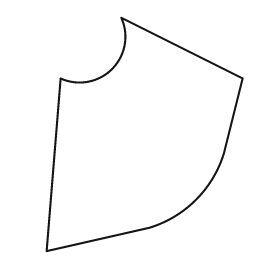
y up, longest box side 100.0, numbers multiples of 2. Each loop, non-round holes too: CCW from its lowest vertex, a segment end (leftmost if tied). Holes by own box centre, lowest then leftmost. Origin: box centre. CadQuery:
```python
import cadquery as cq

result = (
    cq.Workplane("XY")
    .moveTo(-42.0, -50.0)
    .lineTo(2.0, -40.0)
    .threePointArc((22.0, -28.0), (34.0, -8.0))
    .lineTo(42.0, 24.0)
    .lineTo(-10.0, 50.0)
    .threePointArc((-14.0, 28.0), (-36.0, 24.0))
    .close()
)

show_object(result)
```